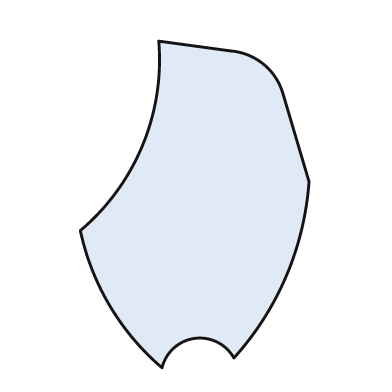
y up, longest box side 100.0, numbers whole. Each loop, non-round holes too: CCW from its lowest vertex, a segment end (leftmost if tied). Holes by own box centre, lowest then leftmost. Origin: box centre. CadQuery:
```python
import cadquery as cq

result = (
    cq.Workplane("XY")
    .moveTo(-10.0, -50.0)
    .threePointArc((0.0, -41.0), (12.0, -47.0))
    .threePointArc((28.0, -22.0), (35.0, 7.0))
    .lineTo(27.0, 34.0)
    .threePointArc((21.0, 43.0), (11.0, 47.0))
    .lineTo(-11.0, 50.0)
    .threePointArc((-16.0, 18.0), (-35.0, -8.0))
    .threePointArc((-26.0, -31.0), (-10.0, -50.0))
    .close()
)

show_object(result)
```